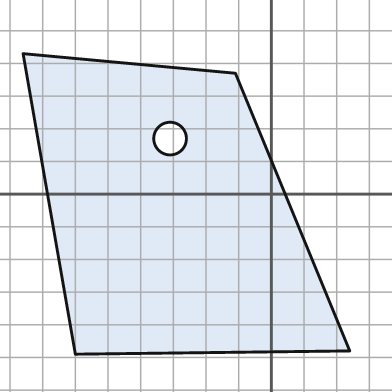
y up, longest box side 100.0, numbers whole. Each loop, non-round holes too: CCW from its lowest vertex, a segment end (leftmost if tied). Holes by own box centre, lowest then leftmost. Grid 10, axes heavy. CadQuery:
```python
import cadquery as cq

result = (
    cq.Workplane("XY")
    .moveTo(-60.0, -49.0)
    .lineTo(24.0, -48.0)
    .lineTo(-11.0, 37.0)
    .lineTo(-76.0, 43.0)
    .close()
    .moveTo(-31.0, 17.0)
    .circle(5.0)
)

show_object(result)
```